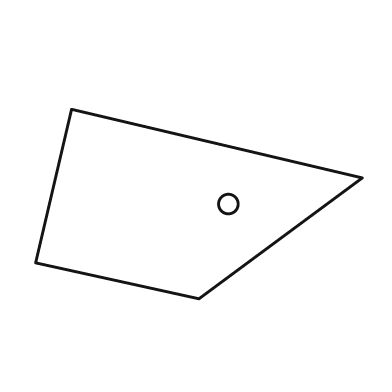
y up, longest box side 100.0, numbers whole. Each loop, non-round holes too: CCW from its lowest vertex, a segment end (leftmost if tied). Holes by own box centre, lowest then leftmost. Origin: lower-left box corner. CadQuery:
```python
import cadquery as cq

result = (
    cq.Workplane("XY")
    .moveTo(50.0, 0.0)
    .lineTo(100.0, 37.0)
    .lineTo(11.0, 58.0)
    .lineTo(0.0, 11.0)
    .close()
    .moveTo(59.0, 29.0)
    .circle(3.0)
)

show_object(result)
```